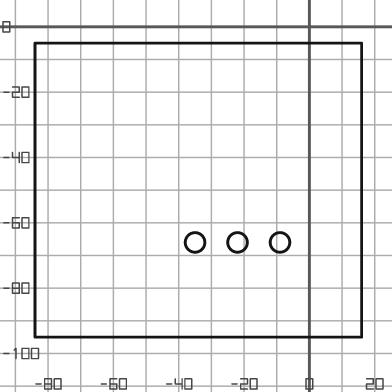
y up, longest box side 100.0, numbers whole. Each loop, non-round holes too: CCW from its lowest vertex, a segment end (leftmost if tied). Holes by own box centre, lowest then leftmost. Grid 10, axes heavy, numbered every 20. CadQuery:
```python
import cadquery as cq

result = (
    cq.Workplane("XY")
    .moveTo(-84.0, -95.0)
    .lineTo(16.0, -95.0)
    .lineTo(16.0, -5.0)
    .lineTo(-84.0, -5.0)
    .close()
    .moveTo(-35.0, -66.0)
    .circle(3.0)
    .moveTo(-22.0, -66.0)
    .circle(3.0)
    .moveTo(-9.0, -66.0)
    .circle(3.0)
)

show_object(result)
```